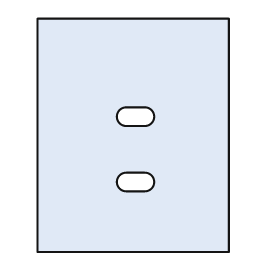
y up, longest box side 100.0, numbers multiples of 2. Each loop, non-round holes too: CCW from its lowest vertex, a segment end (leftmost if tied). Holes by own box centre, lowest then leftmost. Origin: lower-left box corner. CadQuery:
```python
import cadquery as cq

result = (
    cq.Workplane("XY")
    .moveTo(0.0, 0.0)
    .lineTo(82.0, 0.0)
    .lineTo(82.0, 100.0)
    .lineTo(0.0, 100.0)
    .close()
    .moveTo(38.0, 26.0)
    .lineTo(46.0, 26.0)
    .threePointArc((50.0, 30.0), (46.0, 34.0))
    .lineTo(38.0, 34.0)
    .threePointArc((34.0, 30.0), (38.0, 26.0))
    .close()
    .moveTo(38.0, 54.0)
    .lineTo(46.0, 54.0)
    .threePointArc((50.0, 58.0), (46.0, 62.0))
    .lineTo(38.0, 62.0)
    .threePointArc((34.0, 58.0), (38.0, 54.0))
    .close()
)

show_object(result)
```